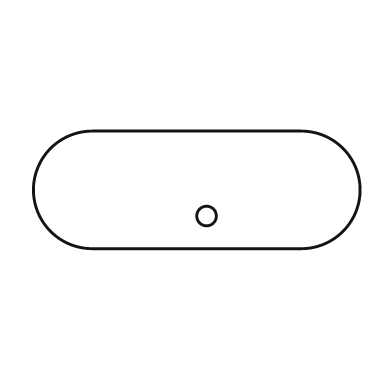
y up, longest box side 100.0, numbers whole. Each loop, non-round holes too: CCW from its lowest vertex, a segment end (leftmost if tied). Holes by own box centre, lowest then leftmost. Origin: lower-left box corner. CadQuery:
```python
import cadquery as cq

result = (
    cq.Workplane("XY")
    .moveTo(18.0, 0.0)
    .lineTo(82.0, 0.0)
    .threePointArc((100.0, 18.0), (82.0, 36.0))
    .lineTo(18.0, 36.0)
    .threePointArc((0.0, 18.0), (18.0, 0.0))
    .close()
    .moveTo(53.0, 10.0)
    .circle(3.0)
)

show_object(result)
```